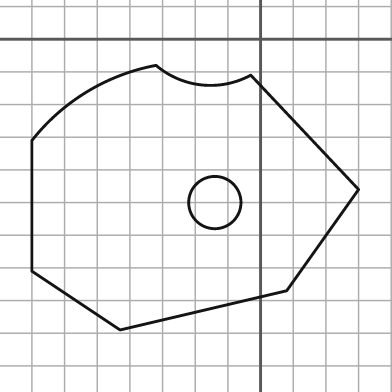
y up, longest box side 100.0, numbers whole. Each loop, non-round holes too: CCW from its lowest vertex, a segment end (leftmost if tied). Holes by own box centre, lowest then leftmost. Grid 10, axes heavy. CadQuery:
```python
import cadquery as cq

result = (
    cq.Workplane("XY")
    .moveTo(-43.0, -89.0)
    .lineTo(8.0, -77.0)
    .lineTo(30.0, -46.0)
    .lineTo(-3.0, -11.0)
    .threePointArc((-18.0, -14.0), (-32.0, -8.0))
    .threePointArc((-53.0, -16.0), (-70.0, -31.0))
    .lineTo(-70.0, -71.0)
    .close()
    .moveTo(-14.0, -50.0)
    .circle(8.0)
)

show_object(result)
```